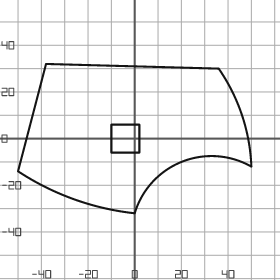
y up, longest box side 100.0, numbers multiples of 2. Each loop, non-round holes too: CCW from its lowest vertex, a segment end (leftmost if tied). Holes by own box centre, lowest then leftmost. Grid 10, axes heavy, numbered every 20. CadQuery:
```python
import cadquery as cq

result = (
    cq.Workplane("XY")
    .moveTo(0.0, -32.0)
    .threePointArc((20.0, -10.0), (50.0, -12.0))
    .threePointArc((46.0, 10.0), (36.0, 30.0))
    .lineTo(-38.0, 32.0)
    .lineTo(-50.0, -14.0)
    .threePointArc((-26.0, -26.0), (0.0, -32.0))
    .close()
    .moveTo(-10.0, -6.0)
    .lineTo(2.0, -6.0)
    .lineTo(2.0, 6.0)
    .lineTo(-10.0, 6.0)
    .close()
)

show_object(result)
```